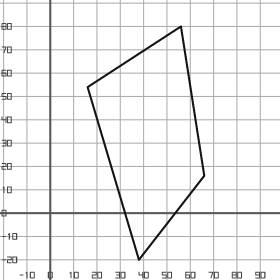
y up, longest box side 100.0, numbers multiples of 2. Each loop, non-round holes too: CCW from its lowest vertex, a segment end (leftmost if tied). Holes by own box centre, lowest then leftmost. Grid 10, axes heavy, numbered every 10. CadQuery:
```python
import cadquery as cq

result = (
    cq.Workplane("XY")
    .moveTo(38.0, -20.0)
    .lineTo(66.0, 16.0)
    .lineTo(56.0, 80.0)
    .lineTo(16.0, 54.0)
    .close()
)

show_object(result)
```